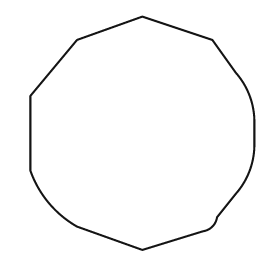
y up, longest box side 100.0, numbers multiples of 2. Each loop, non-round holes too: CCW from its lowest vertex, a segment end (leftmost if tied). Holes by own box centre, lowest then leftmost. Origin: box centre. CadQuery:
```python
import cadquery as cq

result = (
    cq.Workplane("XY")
    .moveTo(0.0, -50.0)
    .lineTo(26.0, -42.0)
    .threePointArc((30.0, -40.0), (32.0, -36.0))
    .lineTo(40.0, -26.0)
    .threePointArc((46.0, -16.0), (48.0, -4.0))
    .lineTo(48.0, 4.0)
    .threePointArc((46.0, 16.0), (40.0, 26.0))
    .lineTo(30.0, 40.0)
    .lineTo(0.0, 50.0)
    .lineTo(-28.0, 40.0)
    .lineTo(-48.0, 16.0)
    .lineTo(-48.0, -16.0)
    .threePointArc((-40.0, -30.0), (-28.0, -40.0))
    .close()
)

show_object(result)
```